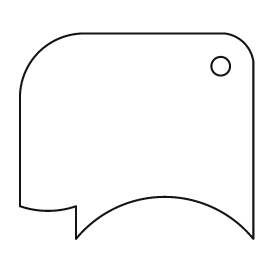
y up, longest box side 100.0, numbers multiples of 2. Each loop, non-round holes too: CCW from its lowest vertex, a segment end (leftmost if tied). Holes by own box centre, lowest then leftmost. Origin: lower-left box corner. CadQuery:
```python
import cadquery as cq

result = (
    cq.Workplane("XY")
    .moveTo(24.0, 0.0)
    .threePointArc((62.0, 18.0), (100.0, 0.0))
    .lineTo(100.0, 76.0)
    .threePointArc((96.0, 84.0), (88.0, 88.0))
    .lineTo(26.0, 88.0)
    .threePointArc((8.0, 80.0), (0.0, 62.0))
    .lineTo(0.0, 14.0)
    .threePointArc((12.0, 12.0), (24.0, 14.0))
    .close()
    .moveTo(86.0, 74.0)
    .circle(4.0)
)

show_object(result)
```